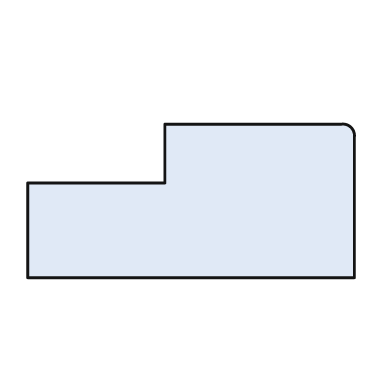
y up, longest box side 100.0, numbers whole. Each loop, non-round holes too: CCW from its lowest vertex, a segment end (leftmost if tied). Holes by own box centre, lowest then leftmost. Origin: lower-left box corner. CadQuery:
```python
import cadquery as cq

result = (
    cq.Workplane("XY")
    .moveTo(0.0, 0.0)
    .lineTo(100.0, 0.0)
    .lineTo(100.0, 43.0)
    .threePointArc((99.0, 46.0), (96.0, 47.0))
    .lineTo(42.0, 47.0)
    .lineTo(42.0, 29.0)
    .lineTo(0.0, 29.0)
    .close()
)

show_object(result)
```